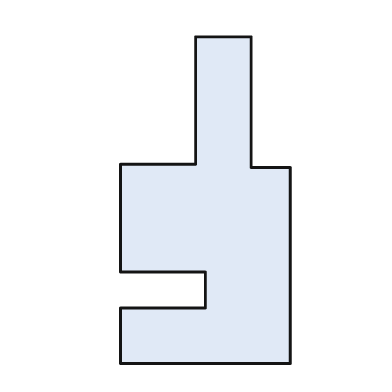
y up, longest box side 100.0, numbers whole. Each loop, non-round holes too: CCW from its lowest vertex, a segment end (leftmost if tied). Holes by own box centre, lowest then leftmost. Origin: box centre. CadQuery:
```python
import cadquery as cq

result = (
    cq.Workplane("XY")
    .moveTo(-26.0, -50.0)
    .lineTo(26.0, -50.0)
    .lineTo(26.0, 10.0)
    .lineTo(14.0, 10.0)
    .lineTo(14.0, 50.0)
    .lineTo(-3.0, 50.0)
    .lineTo(-3.0, 11.0)
    .lineTo(-26.0, 11.0)
    .lineTo(-26.0, -22.0)
    .lineTo(0.0, -22.0)
    .lineTo(0.0, -33.0)
    .lineTo(-26.0, -33.0)
    .close()
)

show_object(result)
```